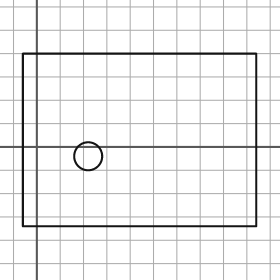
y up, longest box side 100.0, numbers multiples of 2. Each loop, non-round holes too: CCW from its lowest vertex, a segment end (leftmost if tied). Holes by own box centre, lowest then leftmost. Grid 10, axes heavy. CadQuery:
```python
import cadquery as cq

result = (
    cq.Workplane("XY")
    .moveTo(-6.0, -34.0)
    .lineTo(94.0, -34.0)
    .lineTo(94.0, 40.0)
    .lineTo(-6.0, 40.0)
    .close()
    .moveTo(22.0, -4.0)
    .circle(6.0)
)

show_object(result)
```